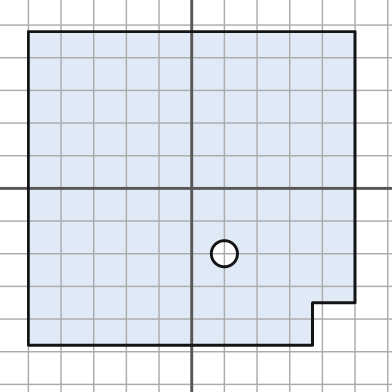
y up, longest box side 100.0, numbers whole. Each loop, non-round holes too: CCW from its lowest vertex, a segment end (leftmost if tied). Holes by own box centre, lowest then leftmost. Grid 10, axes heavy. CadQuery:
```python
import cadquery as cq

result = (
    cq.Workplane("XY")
    .moveTo(-50.0, -48.0)
    .lineTo(37.0, -48.0)
    .lineTo(37.0, -35.0)
    .lineTo(50.0, -35.0)
    .lineTo(50.0, 48.0)
    .lineTo(-50.0, 48.0)
    .close()
    .moveTo(10.0, -20.0)
    .circle(4.0)
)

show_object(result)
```